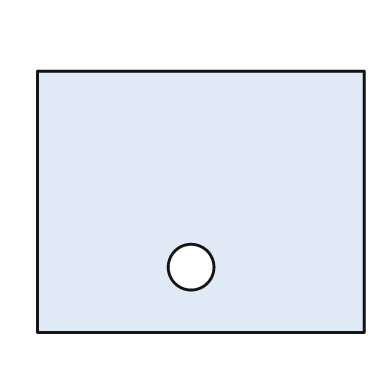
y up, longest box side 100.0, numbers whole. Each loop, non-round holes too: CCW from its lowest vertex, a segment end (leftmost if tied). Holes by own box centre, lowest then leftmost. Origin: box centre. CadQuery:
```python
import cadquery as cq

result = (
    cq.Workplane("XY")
    .moveTo(-50.0, -40.0)
    .lineTo(50.0, -40.0)
    .lineTo(50.0, 40.0)
    .lineTo(-50.0, 40.0)
    .close()
    .moveTo(-3.0, -20.0)
    .circle(7.0)
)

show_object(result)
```